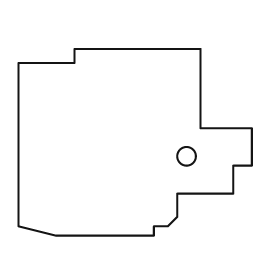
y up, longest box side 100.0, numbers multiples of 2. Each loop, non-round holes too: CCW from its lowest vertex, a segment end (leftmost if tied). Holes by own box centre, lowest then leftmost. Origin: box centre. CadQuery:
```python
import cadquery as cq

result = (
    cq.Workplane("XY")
    .moveTo(-34.0, -40.0)
    .lineTo(8.0, -40.0)
    .lineTo(8.0, -36.0)
    .lineTo(14.0, -36.0)
    .lineTo(18.0, -32.0)
    .lineTo(18.0, -22.0)
    .lineTo(42.0, -22.0)
    .lineTo(42.0, -10.0)
    .lineTo(50.0, -10.0)
    .lineTo(50.0, 6.0)
    .lineTo(28.0, 6.0)
    .lineTo(28.0, 40.0)
    .lineTo(-26.0, 40.0)
    .lineTo(-26.0, 34.0)
    .lineTo(-50.0, 34.0)
    .lineTo(-50.0, -36.0)
    .close()
    .moveTo(22.0, -6.0)
    .circle(4.0)
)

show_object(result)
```